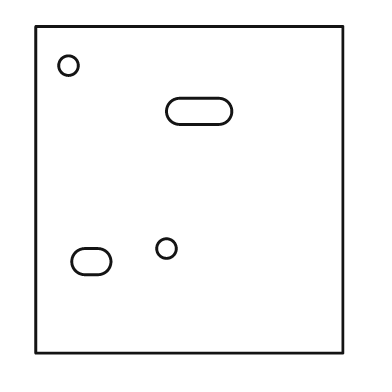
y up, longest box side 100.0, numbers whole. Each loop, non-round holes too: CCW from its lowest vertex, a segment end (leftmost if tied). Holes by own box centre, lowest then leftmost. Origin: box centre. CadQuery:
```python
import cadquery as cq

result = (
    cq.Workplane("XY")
    .moveTo(-47.0, -50.0)
    .lineTo(47.0, -50.0)
    .lineTo(47.0, 50.0)
    .lineTo(-47.0, 50.0)
    .close()
    .moveTo(-32.0, -26.0)
    .lineTo(-28.0, -26.0)
    .threePointArc((-24.0, -22.0), (-28.0, -18.0))
    .lineTo(-32.0, -18.0)
    .threePointArc((-36.0, -22.0), (-32.0, -26.0))
    .close()
    .moveTo(-7.0, -18.0)
    .circle(3.0)
    .moveTo(-3.0, 20.0)
    .lineTo(9.0, 20.0)
    .threePointArc((13.0, 24.0), (9.0, 28.0))
    .lineTo(-3.0, 28.0)
    .threePointArc((-7.0, 24.0), (-3.0, 20.0))
    .close()
    .moveTo(-37.0, 38.0)
    .circle(3.0)
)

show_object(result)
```